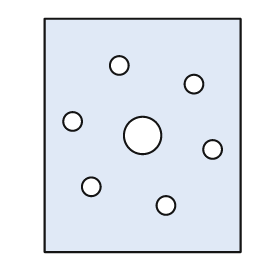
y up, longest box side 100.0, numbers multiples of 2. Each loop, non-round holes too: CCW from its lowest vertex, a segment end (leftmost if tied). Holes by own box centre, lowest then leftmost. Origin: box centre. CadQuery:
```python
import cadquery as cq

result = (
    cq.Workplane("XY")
    .moveTo(-42.0, -50.0)
    .lineTo(42.0, -50.0)
    .lineTo(42.0, 50.0)
    .lineTo(-42.0, 50.0)
    .close()
    .moveTo(10.0, -30.0)
    .circle(4.0)
    .moveTo(-22.0, -22.0)
    .circle(4.0)
    .moveTo(30.0, -6.0)
    .circle(4.0)
    .moveTo(0.0, 0.0)
    .circle(8.0)
    .moveTo(-30.0, 6.0)
    .circle(4.0)
    .moveTo(22.0, 22.0)
    .circle(4.0)
    .moveTo(-10.0, 30.0)
    .circle(4.0)
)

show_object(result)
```